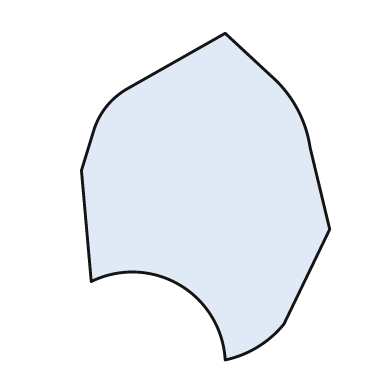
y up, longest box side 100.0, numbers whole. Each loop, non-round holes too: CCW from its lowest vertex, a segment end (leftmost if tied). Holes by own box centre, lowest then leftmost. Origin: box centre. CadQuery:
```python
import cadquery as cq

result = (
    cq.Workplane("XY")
    .moveTo(6.0, -50.0)
    .threePointArc((16.0, -46.0), (24.0, -39.0))
    .lineTo(38.0, -10.0)
    .lineTo(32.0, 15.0)
    .threePointArc((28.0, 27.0), (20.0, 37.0))
    .lineTo(6.0, 50.0)
    .lineTo(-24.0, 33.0)
    .threePointArc((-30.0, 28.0), (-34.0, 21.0))
    .lineTo(-38.0, 8.0)
    .lineTo(-35.0, -26.0)
    .threePointArc((-8.0, -27.0), (6.0, -50.0))
    .close()
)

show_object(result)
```